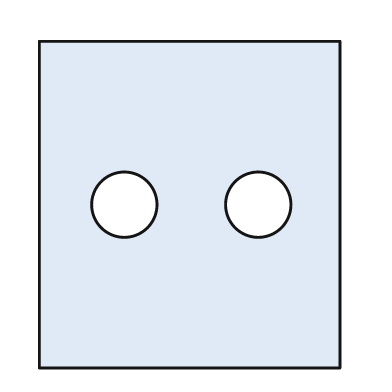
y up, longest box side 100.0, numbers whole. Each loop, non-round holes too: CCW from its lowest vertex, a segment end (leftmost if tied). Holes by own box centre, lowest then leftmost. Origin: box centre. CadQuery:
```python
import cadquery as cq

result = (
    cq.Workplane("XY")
    .moveTo(-46.0, -50.0)
    .lineTo(46.0, -50.0)
    .lineTo(46.0, 50.0)
    .lineTo(-46.0, 50.0)
    .close()
    .moveTo(-20.0, 0.0)
    .circle(10.0)
    .moveTo(21.0, 0.0)
    .circle(10.0)
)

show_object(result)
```